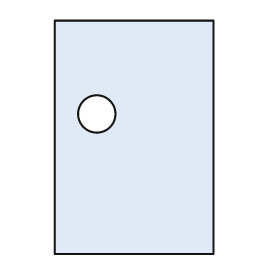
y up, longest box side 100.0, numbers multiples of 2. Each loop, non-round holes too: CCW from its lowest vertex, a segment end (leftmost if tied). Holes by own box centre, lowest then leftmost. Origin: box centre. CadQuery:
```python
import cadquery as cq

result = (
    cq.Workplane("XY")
    .moveTo(-34.0, -50.0)
    .lineTo(34.0, -50.0)
    .lineTo(34.0, 50.0)
    .lineTo(-34.0, 50.0)
    .close()
    .moveTo(-16.0, 10.0)
    .circle(8.0)
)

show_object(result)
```